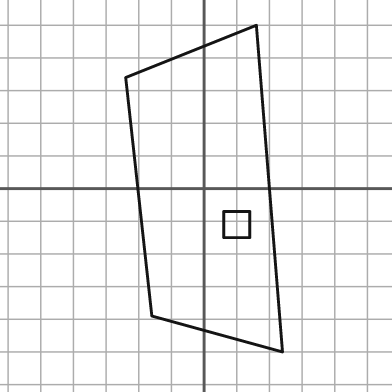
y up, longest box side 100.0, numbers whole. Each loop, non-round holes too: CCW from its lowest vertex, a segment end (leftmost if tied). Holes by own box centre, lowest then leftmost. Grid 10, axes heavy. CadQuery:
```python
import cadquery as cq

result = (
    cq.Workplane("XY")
    .moveTo(24.0, -50.0)
    .lineTo(16.0, 50.0)
    .lineTo(-24.0, 34.0)
    .lineTo(-16.0, -39.0)
    .close()
    .moveTo(6.0, -15.0)
    .lineTo(14.0, -15.0)
    .lineTo(14.0, -7.0)
    .lineTo(6.0, -7.0)
    .close()
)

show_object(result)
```